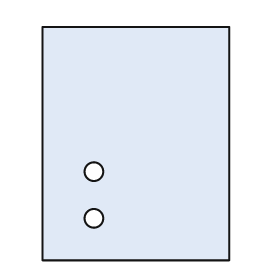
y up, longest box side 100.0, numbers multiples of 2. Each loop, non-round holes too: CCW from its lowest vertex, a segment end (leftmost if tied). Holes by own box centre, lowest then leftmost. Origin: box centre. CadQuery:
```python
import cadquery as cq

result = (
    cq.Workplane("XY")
    .moveTo(-40.0, -50.0)
    .lineTo(40.0, -50.0)
    .lineTo(40.0, 50.0)
    .lineTo(-40.0, 50.0)
    .close()
    .moveTo(-18.0, -32.0)
    .circle(4.0)
    .moveTo(-18.0, -12.0)
    .circle(4.0)
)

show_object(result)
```